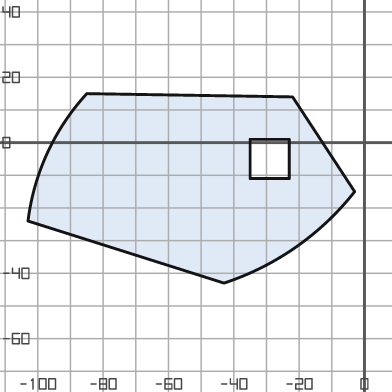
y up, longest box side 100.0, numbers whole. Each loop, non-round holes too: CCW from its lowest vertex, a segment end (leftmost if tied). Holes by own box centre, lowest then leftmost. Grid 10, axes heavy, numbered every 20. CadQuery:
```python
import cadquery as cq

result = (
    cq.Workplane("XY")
    .moveTo(-43.0, -43.0)
    .threePointArc((-21.0, -32.0), (-3.0, -15.0))
    .lineTo(-22.0, 14.0)
    .lineTo(-85.0, 15.0)
    .threePointArc((-97.0, -3.0), (-103.0, -24.0))
    .close()
    .moveTo(-35.0, -11.0)
    .lineTo(-23.0, -11.0)
    .lineTo(-23.0, 1.0)
    .lineTo(-35.0, 1.0)
    .close()
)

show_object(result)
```